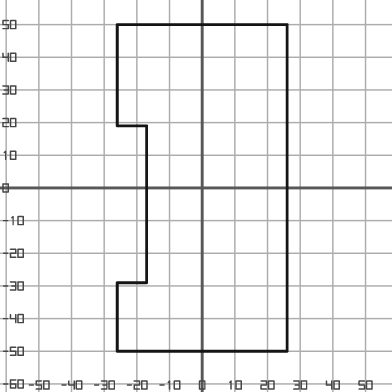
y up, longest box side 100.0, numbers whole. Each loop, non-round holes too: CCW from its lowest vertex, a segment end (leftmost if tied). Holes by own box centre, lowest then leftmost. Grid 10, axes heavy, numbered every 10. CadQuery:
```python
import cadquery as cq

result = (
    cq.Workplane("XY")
    .moveTo(-26.0, -50.0)
    .lineTo(26.0, -50.0)
    .lineTo(26.0, 50.0)
    .lineTo(-26.0, 50.0)
    .lineTo(-26.0, 19.0)
    .lineTo(-17.0, 19.0)
    .lineTo(-17.0, -29.0)
    .lineTo(-26.0, -29.0)
    .close()
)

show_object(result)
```